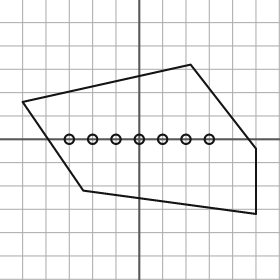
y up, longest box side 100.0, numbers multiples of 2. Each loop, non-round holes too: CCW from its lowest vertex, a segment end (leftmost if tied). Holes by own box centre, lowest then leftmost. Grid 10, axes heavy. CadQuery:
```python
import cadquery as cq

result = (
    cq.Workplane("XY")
    .moveTo(50.0, -32.0)
    .lineTo(50.0, -4.0)
    .lineTo(22.0, 32.0)
    .lineTo(-50.0, 16.0)
    .lineTo(-24.0, -22.0)
    .close()
    .moveTo(-30.0, 0.0)
    .circle(2.0)
    .moveTo(-20.0, 0.0)
    .circle(2.0)
    .moveTo(-10.0, 0.0)
    .circle(2.0)
    .moveTo(0.0, 0.0)
    .circle(2.0)
    .moveTo(10.0, 0.0)
    .circle(2.0)
    .moveTo(20.0, 0.0)
    .circle(2.0)
    .moveTo(30.0, 0.0)
    .circle(2.0)
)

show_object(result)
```